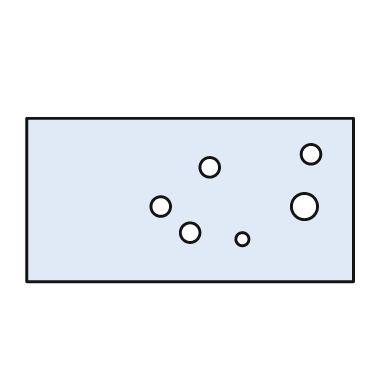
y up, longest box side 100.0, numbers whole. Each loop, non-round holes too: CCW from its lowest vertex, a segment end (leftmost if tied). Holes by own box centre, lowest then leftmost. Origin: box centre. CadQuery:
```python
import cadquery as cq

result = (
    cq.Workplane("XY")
    .moveTo(-50.0, -25.0)
    .lineTo(50.0, -25.0)
    .lineTo(50.0, 25.0)
    .lineTo(-50.0, 25.0)
    .close()
    .moveTo(16.0, -12.0)
    .circle(2.0)
    .moveTo(0.0, -10.0)
    .circle(3.0)
    .moveTo(-9.0, -2.0)
    .circle(3.0)
    .moveTo(35.0, -2.0)
    .circle(4.0)
    .moveTo(6.0, 10.0)
    .circle(3.0)
    .moveTo(37.0, 14.0)
    .circle(3.0)
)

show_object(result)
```